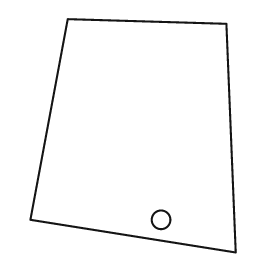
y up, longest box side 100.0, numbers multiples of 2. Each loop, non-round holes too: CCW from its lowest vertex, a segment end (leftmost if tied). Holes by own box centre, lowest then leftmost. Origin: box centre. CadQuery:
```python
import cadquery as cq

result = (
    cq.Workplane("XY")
    .moveTo(44.0, -50.0)
    .lineTo(40.0, 48.0)
    .lineTo(-28.0, 50.0)
    .lineTo(-44.0, -36.0)
    .close()
    .moveTo(12.0, -36.0)
    .circle(4.0)
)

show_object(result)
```